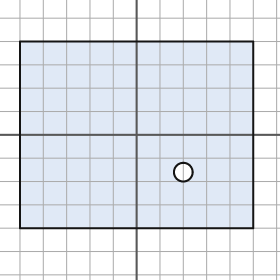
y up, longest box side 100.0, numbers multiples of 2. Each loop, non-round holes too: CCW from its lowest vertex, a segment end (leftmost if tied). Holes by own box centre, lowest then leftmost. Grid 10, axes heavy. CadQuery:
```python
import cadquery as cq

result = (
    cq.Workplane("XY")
    .moveTo(-50.0, -40.0)
    .lineTo(50.0, -40.0)
    .lineTo(50.0, 40.0)
    .lineTo(-50.0, 40.0)
    .close()
    .moveTo(20.0, -16.0)
    .circle(4.0)
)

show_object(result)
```